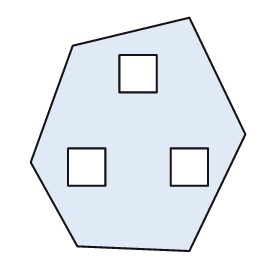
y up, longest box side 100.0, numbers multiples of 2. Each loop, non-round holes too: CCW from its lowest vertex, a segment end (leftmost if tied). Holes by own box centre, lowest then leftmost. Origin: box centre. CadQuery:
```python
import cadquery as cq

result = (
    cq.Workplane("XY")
    .moveTo(22.0, -50.0)
    .lineTo(46.0, 0.0)
    .lineTo(22.0, 50.0)
    .lineTo(-28.0, 38.0)
    .lineTo(-46.0, -12.0)
    .lineTo(-26.0, -48.0)
    .close()
    .moveTo(-30.0, -22.0)
    .lineTo(-14.0, -22.0)
    .lineTo(-14.0, -6.0)
    .lineTo(-30.0, -6.0)
    .close()
    .moveTo(14.0, -22.0)
    .lineTo(30.0, -22.0)
    .lineTo(30.0, -6.0)
    .lineTo(14.0, -6.0)
    .close()
    .moveTo(-8.0, 18.0)
    .lineTo(8.0, 18.0)
    .lineTo(8.0, 34.0)
    .lineTo(-8.0, 34.0)
    .close()
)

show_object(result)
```